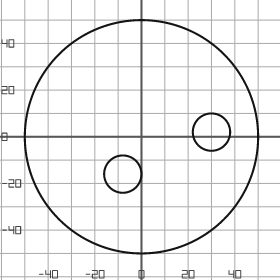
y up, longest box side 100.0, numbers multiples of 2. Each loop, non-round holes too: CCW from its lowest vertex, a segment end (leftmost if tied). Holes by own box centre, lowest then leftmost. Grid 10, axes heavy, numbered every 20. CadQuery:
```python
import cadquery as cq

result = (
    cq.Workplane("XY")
    .moveTo(0.0, 0.0)
    .circle(50.0)
    .moveTo(-8.0, -16.0)
    .circle(8.0)
    .moveTo(30.0, 2.0)
    .circle(8.0)
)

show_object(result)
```